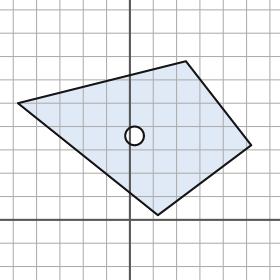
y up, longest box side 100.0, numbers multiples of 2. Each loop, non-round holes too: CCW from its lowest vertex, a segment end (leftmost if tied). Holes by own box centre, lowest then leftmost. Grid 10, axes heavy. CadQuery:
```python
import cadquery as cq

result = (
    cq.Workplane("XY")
    .moveTo(12.0, 2.0)
    .lineTo(52.0, 32.0)
    .lineTo(24.0, 68.0)
    .lineTo(-48.0, 50.0)
    .close()
    .moveTo(2.0, 36.0)
    .circle(4.0)
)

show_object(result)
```